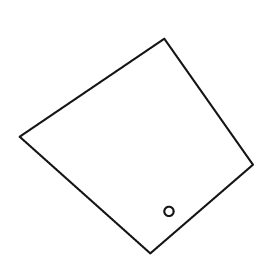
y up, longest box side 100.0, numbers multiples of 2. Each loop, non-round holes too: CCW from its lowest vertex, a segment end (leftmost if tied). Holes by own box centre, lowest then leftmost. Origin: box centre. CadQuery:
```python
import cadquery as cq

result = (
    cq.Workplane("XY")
    .moveTo(6.0, -46.0)
    .lineTo(50.0, -8.0)
    .lineTo(12.0, 46.0)
    .lineTo(-50.0, 4.0)
    .close()
    .moveTo(14.0, -28.0)
    .circle(2.0)
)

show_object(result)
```